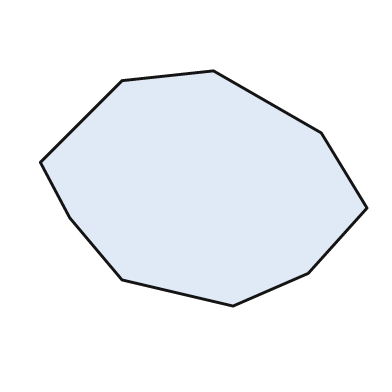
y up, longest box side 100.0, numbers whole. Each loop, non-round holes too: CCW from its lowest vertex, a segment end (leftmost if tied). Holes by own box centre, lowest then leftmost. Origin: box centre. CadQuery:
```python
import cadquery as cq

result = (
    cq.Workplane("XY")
    .moveTo(9.0, -36.0)
    .lineTo(32.0, -26.0)
    .lineTo(50.0, -6.0)
    .lineTo(36.0, 17.0)
    .lineTo(3.0, 36.0)
    .lineTo(-25.0, 33.0)
    .lineTo(-50.0, 8.0)
    .lineTo(-41.0, -9.0)
    .lineTo(-25.0, -28.0)
    .close()
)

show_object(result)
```